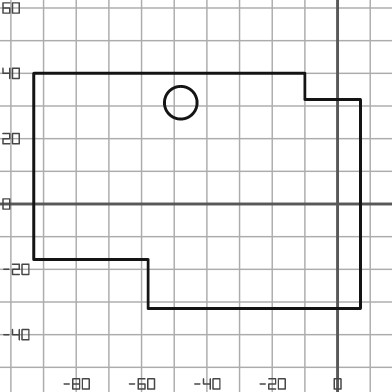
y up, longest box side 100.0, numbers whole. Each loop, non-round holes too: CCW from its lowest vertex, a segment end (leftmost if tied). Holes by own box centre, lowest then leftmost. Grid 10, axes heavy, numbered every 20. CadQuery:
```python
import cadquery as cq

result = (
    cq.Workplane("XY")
    .moveTo(-58.0, -32.0)
    .lineTo(7.0, -32.0)
    .lineTo(7.0, 32.0)
    .lineTo(-10.0, 32.0)
    .lineTo(-10.0, 40.0)
    .lineTo(-93.0, 40.0)
    .lineTo(-93.0, -17.0)
    .lineTo(-58.0, -17.0)
    .close()
    .moveTo(-48.0, 31.0)
    .circle(5.0)
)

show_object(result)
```